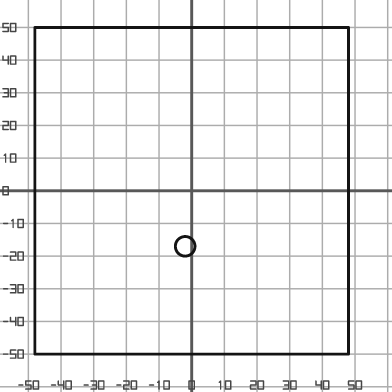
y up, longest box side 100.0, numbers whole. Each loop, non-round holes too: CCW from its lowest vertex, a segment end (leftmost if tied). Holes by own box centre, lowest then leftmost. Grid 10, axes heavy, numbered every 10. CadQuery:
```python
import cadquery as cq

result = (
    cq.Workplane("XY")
    .moveTo(-48.0, -50.0)
    .lineTo(48.0, -50.0)
    .lineTo(48.0, 50.0)
    .lineTo(-48.0, 50.0)
    .close()
    .moveTo(-2.0, -17.0)
    .circle(3.0)
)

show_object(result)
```